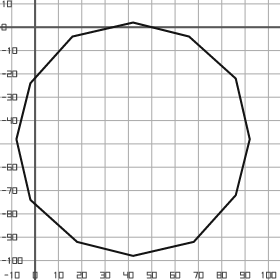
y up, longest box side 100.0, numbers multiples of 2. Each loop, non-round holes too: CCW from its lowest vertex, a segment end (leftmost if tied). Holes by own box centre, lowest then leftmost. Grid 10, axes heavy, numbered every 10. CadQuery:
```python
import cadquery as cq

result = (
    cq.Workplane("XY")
    .moveTo(42.0, -98.0)
    .lineTo(68.0, -92.0)
    .lineTo(86.0, -72.0)
    .lineTo(92.0, -48.0)
    .lineTo(86.0, -22.0)
    .lineTo(66.0, -4.0)
    .lineTo(42.0, 2.0)
    .lineTo(16.0, -4.0)
    .lineTo(-2.0, -24.0)
    .lineTo(-8.0, -48.0)
    .lineTo(-2.0, -74.0)
    .lineTo(18.0, -92.0)
    .close()
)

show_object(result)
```